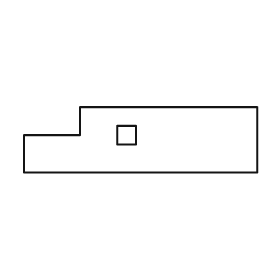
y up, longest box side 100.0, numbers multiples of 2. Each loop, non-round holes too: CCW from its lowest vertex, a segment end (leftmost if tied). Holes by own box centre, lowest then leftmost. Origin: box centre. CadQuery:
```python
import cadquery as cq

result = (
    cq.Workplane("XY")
    .moveTo(-50.0, -14.0)
    .lineTo(50.0, -14.0)
    .lineTo(50.0, 14.0)
    .lineTo(-26.0, 14.0)
    .lineTo(-26.0, 2.0)
    .lineTo(-50.0, 2.0)
    .close()
    .moveTo(-10.0, -2.0)
    .lineTo(-2.0, -2.0)
    .lineTo(-2.0, 6.0)
    .lineTo(-10.0, 6.0)
    .close()
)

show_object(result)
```